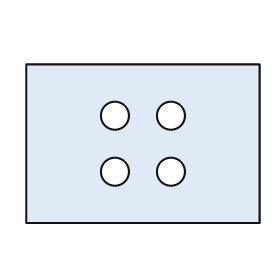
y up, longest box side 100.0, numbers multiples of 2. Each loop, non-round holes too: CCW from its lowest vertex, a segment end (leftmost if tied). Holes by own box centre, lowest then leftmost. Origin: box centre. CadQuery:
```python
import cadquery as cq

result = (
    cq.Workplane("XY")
    .moveTo(-50.0, -34.0)
    .lineTo(50.0, -34.0)
    .lineTo(50.0, 34.0)
    .lineTo(-50.0, 34.0)
    .close()
    .moveTo(-12.0, -12.0)
    .circle(6.0)
    .moveTo(12.0, -12.0)
    .circle(6.0)
    .moveTo(-12.0, 12.0)
    .circle(6.0)
    .moveTo(12.0, 12.0)
    .circle(6.0)
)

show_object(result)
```